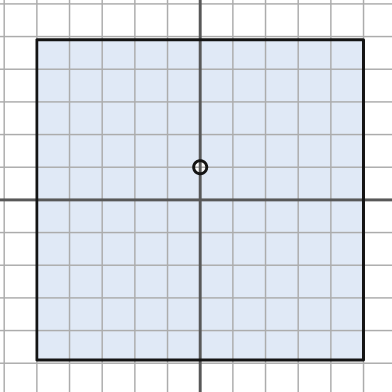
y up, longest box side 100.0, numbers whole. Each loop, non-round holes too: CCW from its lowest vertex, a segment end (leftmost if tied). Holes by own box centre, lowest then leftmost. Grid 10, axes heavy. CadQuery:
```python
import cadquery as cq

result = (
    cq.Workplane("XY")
    .moveTo(-50.0, -49.0)
    .lineTo(50.0, -49.0)
    .lineTo(50.0, 49.0)
    .lineTo(-50.0, 49.0)
    .close()
    .moveTo(0.0, 10.0)
    .circle(2.0)
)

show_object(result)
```